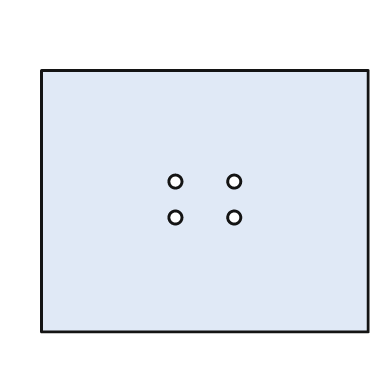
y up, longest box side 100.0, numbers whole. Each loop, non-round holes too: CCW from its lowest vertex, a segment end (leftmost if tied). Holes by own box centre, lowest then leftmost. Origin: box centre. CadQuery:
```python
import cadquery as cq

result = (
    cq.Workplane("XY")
    .moveTo(-50.0, -40.0)
    .lineTo(50.0, -40.0)
    .lineTo(50.0, 40.0)
    .lineTo(-50.0, 40.0)
    .close()
    .moveTo(-9.0, -5.0)
    .circle(2.0)
    .moveTo(9.0, -5.0)
    .circle(2.0)
    .moveTo(-9.0, 6.0)
    .circle(2.0)
    .moveTo(9.0, 6.0)
    .circle(2.0)
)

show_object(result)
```